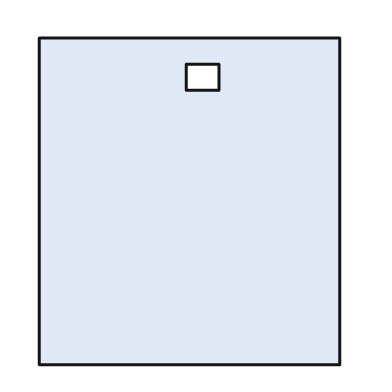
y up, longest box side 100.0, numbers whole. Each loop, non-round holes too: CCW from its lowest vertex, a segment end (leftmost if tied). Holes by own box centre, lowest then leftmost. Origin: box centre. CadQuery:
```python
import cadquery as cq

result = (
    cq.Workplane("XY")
    .moveTo(-46.0, -50.0)
    .lineTo(46.0, -50.0)
    .lineTo(46.0, 50.0)
    .lineTo(-46.0, 50.0)
    .close()
    .moveTo(-1.0, 34.0)
    .lineTo(9.0, 34.0)
    .lineTo(9.0, 42.0)
    .lineTo(-1.0, 42.0)
    .close()
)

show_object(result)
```